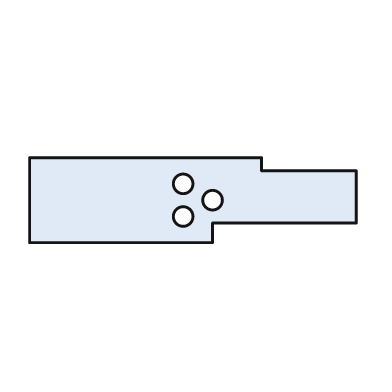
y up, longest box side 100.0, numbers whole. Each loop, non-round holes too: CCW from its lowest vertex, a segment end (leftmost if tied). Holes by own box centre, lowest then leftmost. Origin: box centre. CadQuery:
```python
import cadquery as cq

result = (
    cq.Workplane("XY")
    .moveTo(-50.0, -13.0)
    .lineTo(6.0, -13.0)
    .lineTo(6.0, -7.0)
    .lineTo(50.0, -7.0)
    .lineTo(50.0, 9.0)
    .lineTo(21.0, 9.0)
    .lineTo(21.0, 13.0)
    .lineTo(-50.0, 13.0)
    .close()
    .moveTo(-3.0, -5.0)
    .circle(3.0)
    .moveTo(6.0, 0.0)
    .circle(3.0)
    .moveTo(-3.0, 5.0)
    .circle(3.0)
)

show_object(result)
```